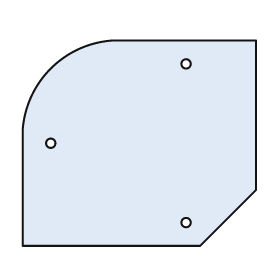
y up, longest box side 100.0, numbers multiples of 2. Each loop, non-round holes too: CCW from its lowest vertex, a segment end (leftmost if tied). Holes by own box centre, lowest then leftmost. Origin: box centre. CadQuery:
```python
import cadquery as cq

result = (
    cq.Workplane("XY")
    .moveTo(-50.0, -44.0)
    .lineTo(26.0, -44.0)
    .lineTo(50.0, -20.0)
    .lineTo(50.0, 44.0)
    .lineTo(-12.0, 44.0)
    .threePointArc((-38.0, 32.0), (-50.0, 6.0))
    .close()
    .moveTo(20.0, -34.0)
    .circle(2.0)
    .moveTo(-38.0, 0.0)
    .circle(2.0)
    .moveTo(20.0, 34.0)
    .circle(2.0)
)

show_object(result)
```